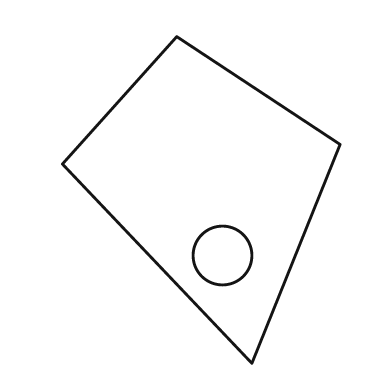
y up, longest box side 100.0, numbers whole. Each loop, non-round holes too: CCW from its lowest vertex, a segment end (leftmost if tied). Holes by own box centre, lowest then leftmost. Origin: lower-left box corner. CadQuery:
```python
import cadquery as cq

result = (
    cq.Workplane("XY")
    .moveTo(58.0, 0.0)
    .lineTo(85.0, 67.0)
    .lineTo(35.0, 100.0)
    .lineTo(0.0, 61.0)
    .close()
    .moveTo(49.0, 33.0)
    .circle(9.0)
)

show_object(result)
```